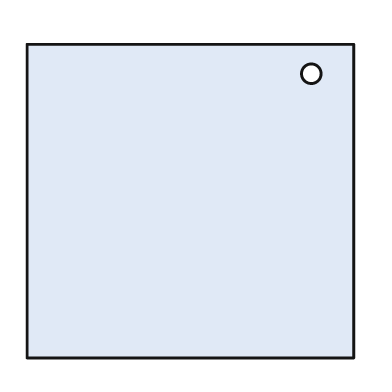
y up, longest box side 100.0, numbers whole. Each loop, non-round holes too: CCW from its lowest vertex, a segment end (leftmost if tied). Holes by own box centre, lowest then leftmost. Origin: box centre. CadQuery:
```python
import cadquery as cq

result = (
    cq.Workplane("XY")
    .moveTo(-50.0, -48.0)
    .lineTo(50.0, -48.0)
    .lineTo(50.0, 48.0)
    .lineTo(-50.0, 48.0)
    .close()
    .moveTo(37.0, 39.0)
    .circle(3.0)
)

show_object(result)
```